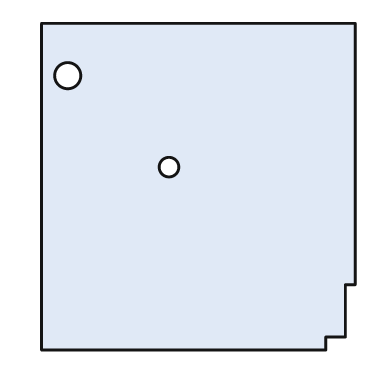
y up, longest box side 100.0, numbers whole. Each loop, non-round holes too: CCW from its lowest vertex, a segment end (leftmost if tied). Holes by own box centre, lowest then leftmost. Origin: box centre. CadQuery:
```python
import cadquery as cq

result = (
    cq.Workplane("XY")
    .moveTo(-48.0, -50.0)
    .lineTo(39.0, -50.0)
    .lineTo(39.0, -46.0)
    .lineTo(45.0, -46.0)
    .lineTo(45.0, -30.0)
    .lineTo(48.0, -30.0)
    .lineTo(48.0, 50.0)
    .lineTo(-48.0, 50.0)
    .close()
    .moveTo(-9.0, 6.0)
    .circle(3.0)
    .moveTo(-40.0, 34.0)
    .circle(4.0)
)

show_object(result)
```